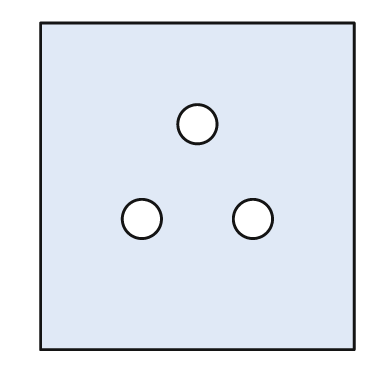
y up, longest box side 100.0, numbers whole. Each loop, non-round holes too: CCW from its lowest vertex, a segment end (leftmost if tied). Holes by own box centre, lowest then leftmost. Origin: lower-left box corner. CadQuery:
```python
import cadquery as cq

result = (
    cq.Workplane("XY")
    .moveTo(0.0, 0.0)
    .lineTo(96.0, 0.0)
    .lineTo(96.0, 100.0)
    .lineTo(0.0, 100.0)
    .close()
    .moveTo(31.0, 40.0)
    .circle(6.0)
    .moveTo(65.0, 40.0)
    .circle(6.0)
    .moveTo(48.0, 69.0)
    .circle(6.0)
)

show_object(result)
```